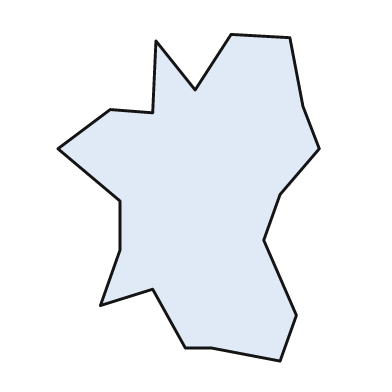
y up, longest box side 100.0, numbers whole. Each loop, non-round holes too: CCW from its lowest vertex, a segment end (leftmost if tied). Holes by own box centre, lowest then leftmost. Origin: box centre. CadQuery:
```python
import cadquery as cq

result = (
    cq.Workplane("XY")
    .moveTo(28.0, -50.0)
    .lineTo(33.0, -36.0)
    .lineTo(23.0, -13.0)
    .lineTo(28.0, 1.0)
    .lineTo(40.0, 15.0)
    .lineTo(35.0, 28.0)
    .lineTo(31.0, 49.0)
    .lineTo(13.0, 50.0)
    .lineTo(2.0, 33.0)
    .lineTo(-10.0, 48.0)
    .lineTo(-11.0, 26.0)
    .lineTo(-24.0, 27.0)
    .lineTo(-40.0, 15.0)
    .lineTo(-21.0, -1.0)
    .lineTo(-21.0, -16.0)
    .lineTo(-27.0, -33.0)
    .lineTo(-11.0, -28.0)
    .lineTo(-1.0, -46.0)
    .lineTo(7.0, -46.0)
    .close()
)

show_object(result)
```